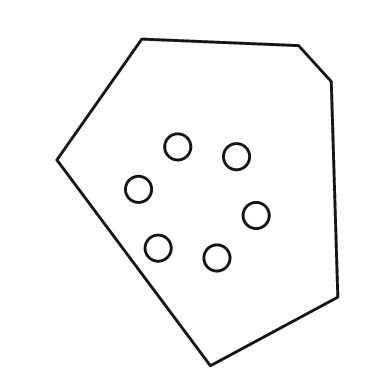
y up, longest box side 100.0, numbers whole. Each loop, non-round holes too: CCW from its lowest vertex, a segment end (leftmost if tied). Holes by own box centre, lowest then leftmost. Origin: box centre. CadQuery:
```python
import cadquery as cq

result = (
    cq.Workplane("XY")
    .moveTo(4.0, -50.0)
    .lineTo(43.0, -29.0)
    .lineTo(41.0, 37.0)
    .lineTo(31.0, 48.0)
    .lineTo(-17.0, 50.0)
    .lineTo(-43.0, 13.0)
    .close()
    .moveTo(6.0, -17.0)
    .circle(4.0)
    .moveTo(-12.0, -14.0)
    .circle(4.0)
    .moveTo(18.0, -4.0)
    .circle(4.0)
    .moveTo(-18.0, 4.0)
    .circle(4.0)
    .moveTo(12.0, 14.0)
    .circle(4.0)
    .moveTo(-6.0, 17.0)
    .circle(4.0)
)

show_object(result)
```